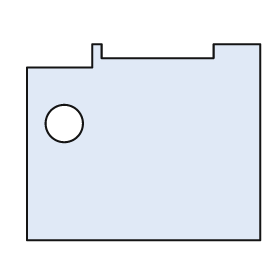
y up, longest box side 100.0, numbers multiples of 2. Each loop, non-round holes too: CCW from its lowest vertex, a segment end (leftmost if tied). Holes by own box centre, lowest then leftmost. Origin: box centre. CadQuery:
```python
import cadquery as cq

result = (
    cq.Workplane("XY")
    .moveTo(-50.0, -42.0)
    .lineTo(50.0, -42.0)
    .lineTo(50.0, 42.0)
    .lineTo(30.0, 42.0)
    .lineTo(30.0, 36.0)
    .lineTo(-18.0, 36.0)
    .lineTo(-18.0, 42.0)
    .lineTo(-22.0, 42.0)
    .lineTo(-22.0, 32.0)
    .lineTo(-50.0, 32.0)
    .close()
    .moveTo(-34.0, 8.0)
    .circle(8.0)
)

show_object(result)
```